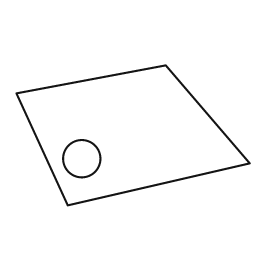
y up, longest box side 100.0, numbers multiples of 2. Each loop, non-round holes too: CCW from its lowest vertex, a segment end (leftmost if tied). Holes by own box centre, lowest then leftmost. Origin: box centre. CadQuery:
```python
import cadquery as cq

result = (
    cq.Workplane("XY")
    .moveTo(-28.0, -30.0)
    .lineTo(50.0, -12.0)
    .lineTo(14.0, 30.0)
    .lineTo(-50.0, 18.0)
    .close()
    .moveTo(-22.0, -10.0)
    .circle(8.0)
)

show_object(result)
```